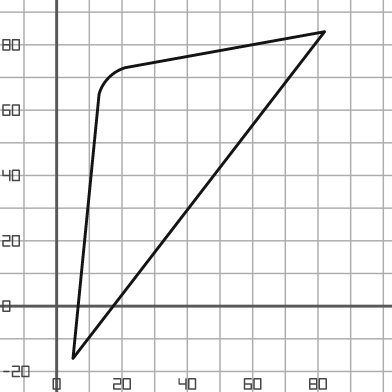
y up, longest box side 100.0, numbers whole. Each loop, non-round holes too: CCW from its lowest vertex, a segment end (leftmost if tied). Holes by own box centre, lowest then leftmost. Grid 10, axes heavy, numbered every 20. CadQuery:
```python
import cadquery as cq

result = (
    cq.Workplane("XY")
    .moveTo(5.0, -16.0)
    .lineTo(82.0, 84.0)
    .lineTo(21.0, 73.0)
    .threePointArc((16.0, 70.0), (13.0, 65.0))
    .close()
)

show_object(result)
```